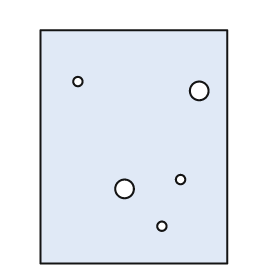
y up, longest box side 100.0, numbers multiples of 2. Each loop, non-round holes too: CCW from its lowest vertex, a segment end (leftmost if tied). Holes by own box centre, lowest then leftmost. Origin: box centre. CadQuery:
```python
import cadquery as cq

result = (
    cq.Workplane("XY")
    .moveTo(-40.0, -50.0)
    .lineTo(40.0, -50.0)
    .lineTo(40.0, 50.0)
    .lineTo(-40.0, 50.0)
    .close()
    .moveTo(12.0, -34.0)
    .circle(2.0)
    .moveTo(-4.0, -18.0)
    .circle(4.0)
    .moveTo(20.0, -14.0)
    .circle(2.0)
    .moveTo(28.0, 24.0)
    .circle(4.0)
    .moveTo(-24.0, 28.0)
    .circle(2.0)
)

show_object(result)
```